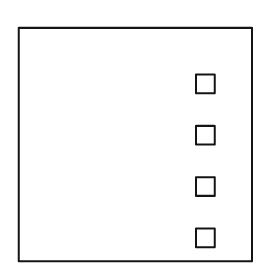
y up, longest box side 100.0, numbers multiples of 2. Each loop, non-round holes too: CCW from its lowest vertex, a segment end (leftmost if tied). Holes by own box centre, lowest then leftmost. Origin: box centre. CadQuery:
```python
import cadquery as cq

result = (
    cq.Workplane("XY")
    .moveTo(-50.0, -50.0)
    .lineTo(50.0, -50.0)
    .lineTo(50.0, 50.0)
    .lineTo(-50.0, 50.0)
    .close()
    .moveTo(26.0, -44.0)
    .lineTo(34.0, -44.0)
    .lineTo(34.0, -36.0)
    .lineTo(26.0, -36.0)
    .close()
    .moveTo(26.0, -22.0)
    .lineTo(34.0, -22.0)
    .lineTo(34.0, -14.0)
    .lineTo(26.0, -14.0)
    .close()
    .moveTo(26.0, 0.0)
    .lineTo(34.0, 0.0)
    .lineTo(34.0, 8.0)
    .lineTo(26.0, 8.0)
    .close()
    .moveTo(26.0, 22.0)
    .lineTo(34.0, 22.0)
    .lineTo(34.0, 30.0)
    .lineTo(26.0, 30.0)
    .close()
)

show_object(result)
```